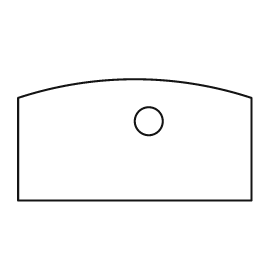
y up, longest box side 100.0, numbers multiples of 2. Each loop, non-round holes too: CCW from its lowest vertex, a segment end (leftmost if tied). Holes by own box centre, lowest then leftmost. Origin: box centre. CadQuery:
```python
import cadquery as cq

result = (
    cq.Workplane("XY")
    .moveTo(-50.0, -26.0)
    .lineTo(50.0, -26.0)
    .lineTo(50.0, 18.0)
    .threePointArc((0.0, 26.0), (-50.0, 18.0))
    .close()
    .moveTo(6.0, 8.0)
    .circle(6.0)
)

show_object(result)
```